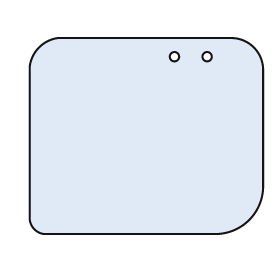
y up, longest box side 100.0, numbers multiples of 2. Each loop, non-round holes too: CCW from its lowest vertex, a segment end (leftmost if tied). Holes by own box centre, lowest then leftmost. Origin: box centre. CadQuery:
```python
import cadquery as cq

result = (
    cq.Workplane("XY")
    .moveTo(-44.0, -42.0)
    .lineTo(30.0, -42.0)
    .threePointArc((44.0, -36.0), (50.0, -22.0))
    .lineTo(50.0, 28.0)
    .threePointArc((46.0, 38.0), (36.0, 42.0))
    .lineTo(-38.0, 42.0)
    .threePointArc((-46.0, 38.0), (-50.0, 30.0))
    .lineTo(-50.0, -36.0)
    .threePointArc((-48.0, -40.0), (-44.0, -42.0))
    .close()
    .moveTo(12.0, 34.0)
    .circle(2.0)
    .moveTo(26.0, 34.0)
    .circle(2.0)
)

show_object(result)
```